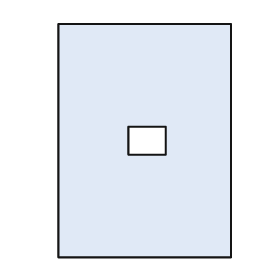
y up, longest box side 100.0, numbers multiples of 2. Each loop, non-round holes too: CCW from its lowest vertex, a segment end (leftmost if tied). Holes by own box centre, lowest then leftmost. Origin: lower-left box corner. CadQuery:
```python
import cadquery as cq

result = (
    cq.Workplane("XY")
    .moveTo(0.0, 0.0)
    .lineTo(74.0, 0.0)
    .lineTo(74.0, 100.0)
    .lineTo(0.0, 100.0)
    .close()
    .moveTo(30.0, 44.0)
    .lineTo(46.0, 44.0)
    .lineTo(46.0, 56.0)
    .lineTo(30.0, 56.0)
    .close()
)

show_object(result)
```